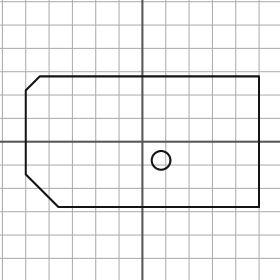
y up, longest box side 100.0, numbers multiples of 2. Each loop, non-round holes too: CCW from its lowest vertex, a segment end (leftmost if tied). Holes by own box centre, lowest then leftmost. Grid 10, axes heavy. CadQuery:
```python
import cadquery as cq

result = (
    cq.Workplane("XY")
    .moveTo(-36.0, -28.0)
    .lineTo(50.0, -28.0)
    .lineTo(50.0, 28.0)
    .lineTo(-44.0, 28.0)
    .lineTo(-50.0, 22.0)
    .lineTo(-50.0, -14.0)
    .close()
    .moveTo(8.0, -8.0)
    .circle(4.0)
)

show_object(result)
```